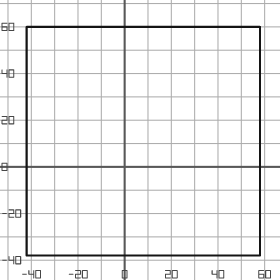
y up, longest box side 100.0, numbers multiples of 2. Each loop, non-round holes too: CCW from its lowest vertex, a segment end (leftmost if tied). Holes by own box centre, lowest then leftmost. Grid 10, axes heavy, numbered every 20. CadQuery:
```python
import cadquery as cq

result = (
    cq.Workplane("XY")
    .moveTo(-42.0, -38.0)
    .lineTo(58.0, -38.0)
    .lineTo(58.0, 60.0)
    .lineTo(-42.0, 60.0)
    .close()
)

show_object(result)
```